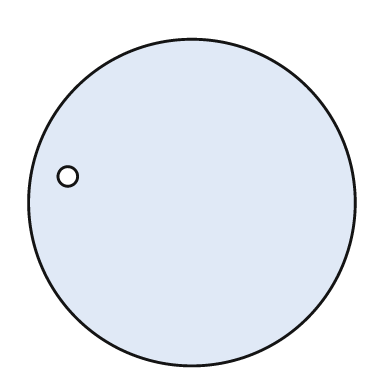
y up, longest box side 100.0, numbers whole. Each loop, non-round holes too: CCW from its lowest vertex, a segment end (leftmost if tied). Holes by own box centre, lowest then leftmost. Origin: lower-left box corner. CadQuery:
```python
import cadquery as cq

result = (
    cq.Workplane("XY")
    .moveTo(50.0, 50.0)
    .circle(50.0)
    .moveTo(12.0, 58.0)
    .circle(3.0)
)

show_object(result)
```